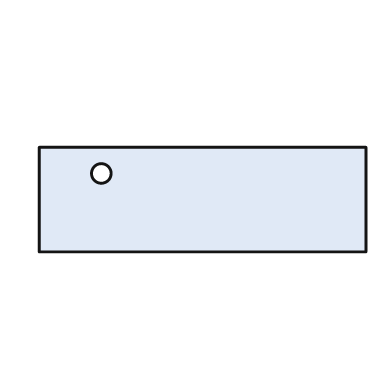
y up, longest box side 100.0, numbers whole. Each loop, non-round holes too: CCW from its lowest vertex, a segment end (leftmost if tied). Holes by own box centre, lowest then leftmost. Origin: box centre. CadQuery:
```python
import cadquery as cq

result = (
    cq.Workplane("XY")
    .moveTo(-50.0, -16.0)
    .lineTo(50.0, -16.0)
    .lineTo(50.0, 16.0)
    .lineTo(-50.0, 16.0)
    .close()
    .moveTo(-31.0, 8.0)
    .circle(3.0)
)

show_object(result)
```